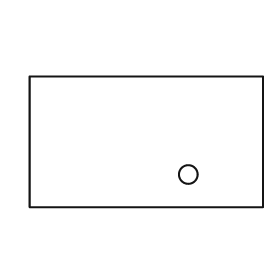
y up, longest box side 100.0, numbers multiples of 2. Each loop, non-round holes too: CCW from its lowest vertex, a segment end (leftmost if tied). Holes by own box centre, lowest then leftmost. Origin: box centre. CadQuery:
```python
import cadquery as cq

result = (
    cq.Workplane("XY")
    .moveTo(-50.0, -28.0)
    .lineTo(50.0, -28.0)
    .lineTo(50.0, 28.0)
    .lineTo(-50.0, 28.0)
    .close()
    .moveTo(18.0, -14.0)
    .circle(4.0)
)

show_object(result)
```